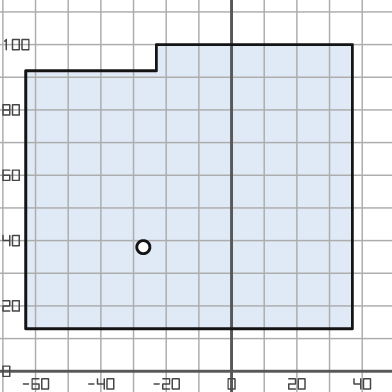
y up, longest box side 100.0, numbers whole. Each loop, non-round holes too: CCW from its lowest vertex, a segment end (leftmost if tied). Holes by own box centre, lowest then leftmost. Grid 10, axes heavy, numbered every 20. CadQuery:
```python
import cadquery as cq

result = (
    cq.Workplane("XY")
    .moveTo(-63.0, 13.0)
    .lineTo(37.0, 13.0)
    .lineTo(37.0, 100.0)
    .lineTo(-23.0, 100.0)
    .lineTo(-23.0, 92.0)
    .lineTo(-63.0, 92.0)
    .close()
    .moveTo(-27.0, 38.0)
    .circle(2.0)
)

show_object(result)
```